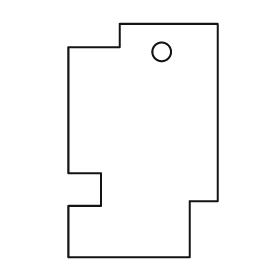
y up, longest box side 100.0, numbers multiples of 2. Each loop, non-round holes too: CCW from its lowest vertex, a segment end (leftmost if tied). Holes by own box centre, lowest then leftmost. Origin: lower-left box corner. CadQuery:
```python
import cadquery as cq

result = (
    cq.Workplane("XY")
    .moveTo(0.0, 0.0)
    .lineTo(52.0, 0.0)
    .lineTo(52.0, 24.0)
    .lineTo(64.0, 24.0)
    .lineTo(64.0, 100.0)
    .lineTo(22.0, 100.0)
    .lineTo(22.0, 90.0)
    .lineTo(0.0, 90.0)
    .lineTo(0.0, 36.0)
    .lineTo(14.0, 36.0)
    .lineTo(14.0, 22.0)
    .lineTo(0.0, 22.0)
    .close()
    .moveTo(40.0, 88.0)
    .circle(4.0)
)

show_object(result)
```